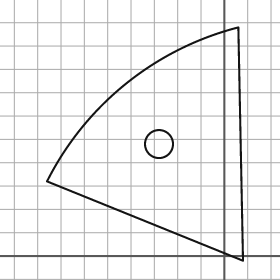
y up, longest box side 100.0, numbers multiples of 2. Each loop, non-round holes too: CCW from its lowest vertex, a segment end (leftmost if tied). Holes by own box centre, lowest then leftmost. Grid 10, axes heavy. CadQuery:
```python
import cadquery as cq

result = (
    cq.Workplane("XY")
    .moveTo(8.0, -2.0)
    .lineTo(6.0, 98.0)
    .threePointArc((-42.0, 74.0), (-76.0, 32.0))
    .close()
    .moveTo(-28.0, 48.0)
    .circle(6.0)
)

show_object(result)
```